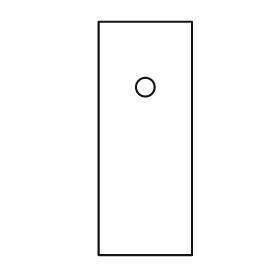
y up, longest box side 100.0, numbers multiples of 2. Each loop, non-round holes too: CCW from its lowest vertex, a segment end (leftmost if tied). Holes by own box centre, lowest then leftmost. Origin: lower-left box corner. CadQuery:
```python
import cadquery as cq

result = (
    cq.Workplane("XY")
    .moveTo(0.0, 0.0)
    .lineTo(40.0, 0.0)
    .lineTo(40.0, 100.0)
    .lineTo(0.0, 100.0)
    .close()
    .moveTo(20.0, 72.0)
    .circle(4.0)
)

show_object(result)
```